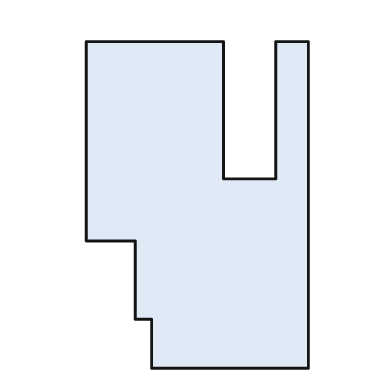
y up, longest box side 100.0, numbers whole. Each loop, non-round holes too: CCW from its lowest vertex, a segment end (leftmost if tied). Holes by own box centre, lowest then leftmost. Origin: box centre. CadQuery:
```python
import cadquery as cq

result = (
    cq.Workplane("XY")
    .moveTo(-14.0, -50.0)
    .lineTo(34.0, -50.0)
    .lineTo(34.0, 50.0)
    .lineTo(24.0, 50.0)
    .lineTo(24.0, 8.0)
    .lineTo(8.0, 8.0)
    .lineTo(8.0, 50.0)
    .lineTo(-34.0, 50.0)
    .lineTo(-34.0, -11.0)
    .lineTo(-19.0, -11.0)
    .lineTo(-19.0, -35.0)
    .lineTo(-14.0, -35.0)
    .close()
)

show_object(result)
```